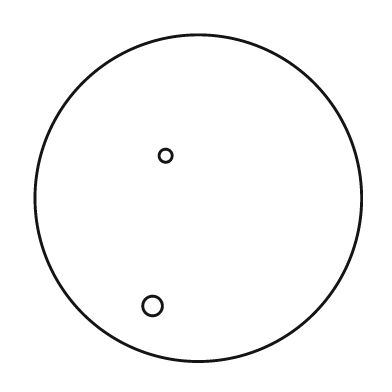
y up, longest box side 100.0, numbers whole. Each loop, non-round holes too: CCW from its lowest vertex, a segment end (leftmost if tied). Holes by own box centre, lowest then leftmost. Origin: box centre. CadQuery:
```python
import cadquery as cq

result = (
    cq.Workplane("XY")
    .moveTo(0.0, 0.0)
    .circle(50.0)
    .moveTo(-14.0, -33.0)
    .circle(3.0)
    .moveTo(-10.0, 13.0)
    .circle(2.0)
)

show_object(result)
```